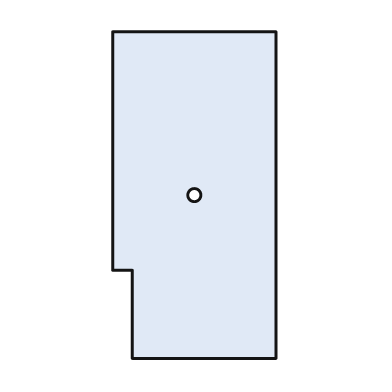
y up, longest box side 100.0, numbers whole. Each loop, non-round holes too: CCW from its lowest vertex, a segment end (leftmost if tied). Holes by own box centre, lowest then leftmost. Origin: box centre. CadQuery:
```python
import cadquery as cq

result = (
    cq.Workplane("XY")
    .moveTo(-19.0, -50.0)
    .lineTo(25.0, -50.0)
    .lineTo(25.0, 50.0)
    .lineTo(-25.0, 50.0)
    .lineTo(-25.0, -23.0)
    .lineTo(-19.0, -23.0)
    .close()
    .moveTo(0.0, 0.0)
    .circle(2.0)
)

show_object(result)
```